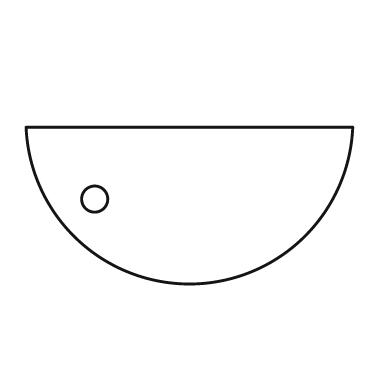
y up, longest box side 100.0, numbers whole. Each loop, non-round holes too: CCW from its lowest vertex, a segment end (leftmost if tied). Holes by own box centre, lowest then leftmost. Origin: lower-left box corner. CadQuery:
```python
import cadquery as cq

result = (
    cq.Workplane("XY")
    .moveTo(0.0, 48.0)
    .threePointArc((50.0, 0.0), (100.0, 48.0))
    .close()
    .moveTo(21.0, 26.0)
    .circle(4.0)
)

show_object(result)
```